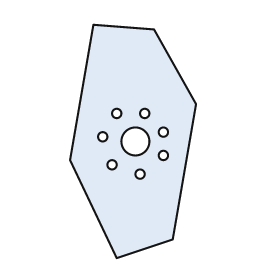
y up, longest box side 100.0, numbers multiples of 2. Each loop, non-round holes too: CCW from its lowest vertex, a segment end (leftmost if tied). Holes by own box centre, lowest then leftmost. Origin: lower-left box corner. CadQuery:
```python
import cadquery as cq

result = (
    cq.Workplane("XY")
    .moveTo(20.0, 0.0)
    .lineTo(44.0, 8.0)
    .lineTo(54.0, 66.0)
    .lineTo(36.0, 98.0)
    .lineTo(10.0, 100.0)
    .lineTo(0.0, 42.0)
    .close()
    .moveTo(30.0, 36.0)
    .circle(2.0)
    .moveTo(18.0, 40.0)
    .circle(2.0)
    .moveTo(40.0, 44.0)
    .circle(2.0)
    .moveTo(28.0, 50.0)
    .circle(6.0)
    .moveTo(14.0, 52.0)
    .circle(2.0)
    .moveTo(40.0, 54.0)
    .circle(2.0)
    .moveTo(20.0, 62.0)
    .circle(2.0)
    .moveTo(32.0, 62.0)
    .circle(2.0)
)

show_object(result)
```